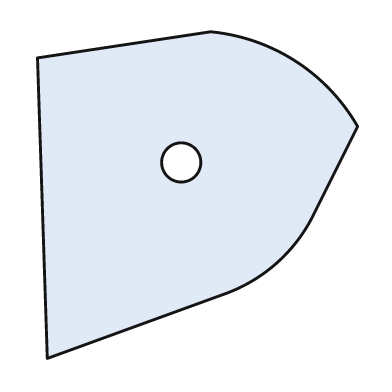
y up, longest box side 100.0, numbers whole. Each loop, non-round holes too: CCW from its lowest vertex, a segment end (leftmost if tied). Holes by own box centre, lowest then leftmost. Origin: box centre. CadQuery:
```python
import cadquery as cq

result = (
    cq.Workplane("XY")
    .moveTo(-46.0, -50.0)
    .lineTo(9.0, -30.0)
    .threePointArc((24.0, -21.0), (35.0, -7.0))
    .lineTo(49.0, 21.0)
    .threePointArc((30.0, 41.0), (4.0, 50.0))
    .lineTo(-49.0, 42.0)
    .close()
    .moveTo(-5.0, 10.0)
    .circle(6.0)
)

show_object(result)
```